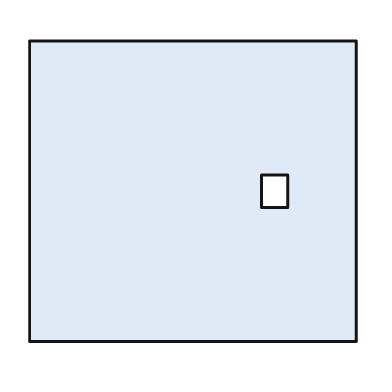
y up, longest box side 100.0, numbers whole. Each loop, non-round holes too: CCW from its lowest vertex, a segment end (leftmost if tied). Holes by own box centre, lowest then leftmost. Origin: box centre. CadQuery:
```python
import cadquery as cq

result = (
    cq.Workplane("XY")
    .moveTo(-50.0, -46.0)
    .lineTo(50.0, -46.0)
    .lineTo(50.0, 46.0)
    .lineTo(-50.0, 46.0)
    .close()
    .moveTo(21.0, -5.0)
    .lineTo(29.0, -5.0)
    .lineTo(29.0, 5.0)
    .lineTo(21.0, 5.0)
    .close()
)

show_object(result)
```